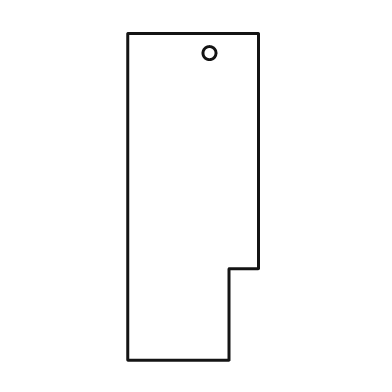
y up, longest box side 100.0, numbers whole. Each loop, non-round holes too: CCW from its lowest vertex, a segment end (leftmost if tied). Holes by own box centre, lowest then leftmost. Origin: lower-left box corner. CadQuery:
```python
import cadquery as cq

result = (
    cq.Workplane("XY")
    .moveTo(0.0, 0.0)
    .lineTo(31.0, 0.0)
    .lineTo(31.0, 28.0)
    .lineTo(40.0, 28.0)
    .lineTo(40.0, 100.0)
    .lineTo(0.0, 100.0)
    .close()
    .moveTo(25.0, 94.0)
    .circle(2.0)
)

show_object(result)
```